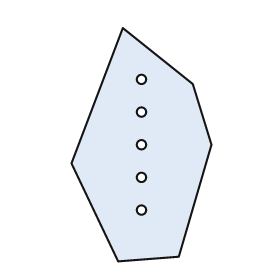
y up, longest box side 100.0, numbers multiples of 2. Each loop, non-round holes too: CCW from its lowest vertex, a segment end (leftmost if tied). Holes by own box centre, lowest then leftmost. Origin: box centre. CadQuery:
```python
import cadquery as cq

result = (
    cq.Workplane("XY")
    .moveTo(-10.0, -50.0)
    .lineTo(16.0, -48.0)
    .lineTo(30.0, 0.0)
    .lineTo(22.0, 26.0)
    .lineTo(-8.0, 50.0)
    .lineTo(-30.0, -8.0)
    .close()
    .moveTo(0.0, -28.0)
    .circle(2.0)
    .moveTo(0.0, -14.0)
    .circle(2.0)
    .moveTo(0.0, 0.0)
    .circle(2.0)
    .moveTo(0.0, 14.0)
    .circle(2.0)
    .moveTo(0.0, 28.0)
    .circle(2.0)
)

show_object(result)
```